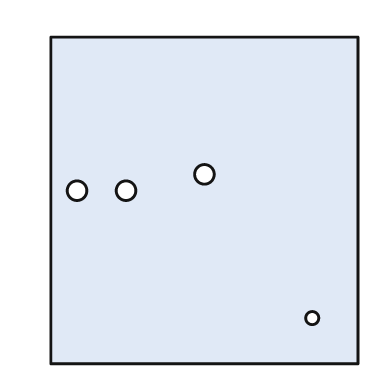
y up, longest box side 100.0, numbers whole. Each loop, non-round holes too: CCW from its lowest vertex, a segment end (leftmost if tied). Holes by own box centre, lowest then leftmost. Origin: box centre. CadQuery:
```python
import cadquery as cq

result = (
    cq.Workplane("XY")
    .moveTo(-47.0, -50.0)
    .lineTo(47.0, -50.0)
    .lineTo(47.0, 50.0)
    .lineTo(-47.0, 50.0)
    .close()
    .moveTo(33.0, -36.0)
    .circle(2.0)
    .moveTo(-39.0, 3.0)
    .circle(3.0)
    .moveTo(-24.0, 3.0)
    .circle(3.0)
    .moveTo(0.0, 8.0)
    .circle(3.0)
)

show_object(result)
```